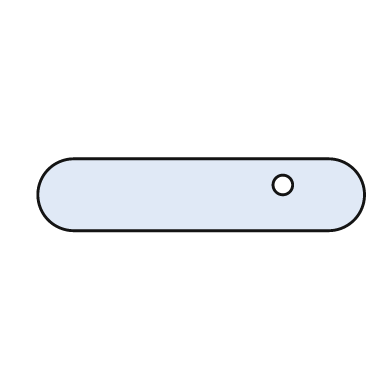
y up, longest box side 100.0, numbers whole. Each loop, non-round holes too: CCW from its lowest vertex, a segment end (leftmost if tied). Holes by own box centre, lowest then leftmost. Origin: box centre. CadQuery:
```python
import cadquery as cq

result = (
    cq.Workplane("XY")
    .moveTo(-39.0, -11.0)
    .lineTo(39.0, -11.0)
    .threePointArc((50.0, 0.0), (39.0, 11.0))
    .lineTo(-39.0, 11.0)
    .threePointArc((-50.0, 0.0), (-39.0, -11.0))
    .close()
    .moveTo(25.0, 3.0)
    .circle(3.0)
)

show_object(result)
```